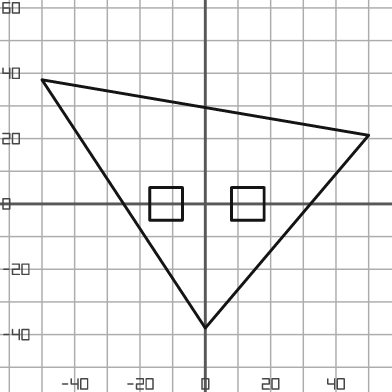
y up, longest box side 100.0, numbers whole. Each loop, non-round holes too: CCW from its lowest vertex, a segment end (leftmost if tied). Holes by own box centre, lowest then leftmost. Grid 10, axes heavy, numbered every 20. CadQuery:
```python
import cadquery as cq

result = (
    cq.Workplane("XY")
    .moveTo(0.0, -38.0)
    .lineTo(50.0, 21.0)
    .lineTo(-50.0, 38.0)
    .close()
    .moveTo(-17.0, -5.0)
    .lineTo(-7.0, -5.0)
    .lineTo(-7.0, 5.0)
    .lineTo(-17.0, 5.0)
    .close()
    .moveTo(8.0, -5.0)
    .lineTo(18.0, -5.0)
    .lineTo(18.0, 5.0)
    .lineTo(8.0, 5.0)
    .close()
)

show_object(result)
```